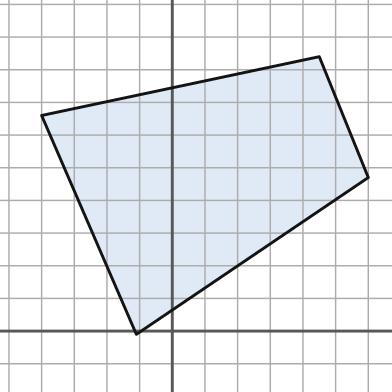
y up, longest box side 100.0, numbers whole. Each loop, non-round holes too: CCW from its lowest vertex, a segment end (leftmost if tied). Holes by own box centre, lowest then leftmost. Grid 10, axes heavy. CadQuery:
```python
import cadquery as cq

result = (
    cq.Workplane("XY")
    .moveTo(-11.0, -1.0)
    .lineTo(60.0, 47.0)
    .lineTo(45.0, 84.0)
    .lineTo(-40.0, 66.0)
    .close()
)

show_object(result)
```